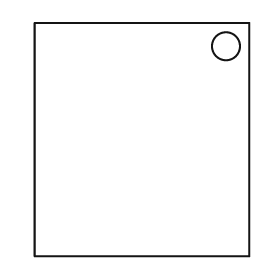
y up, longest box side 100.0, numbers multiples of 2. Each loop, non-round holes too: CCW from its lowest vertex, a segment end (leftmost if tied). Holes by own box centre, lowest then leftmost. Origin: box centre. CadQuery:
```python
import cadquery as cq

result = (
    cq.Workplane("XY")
    .moveTo(-46.0, -50.0)
    .lineTo(46.0, -50.0)
    .lineTo(46.0, 50.0)
    .lineTo(-46.0, 50.0)
    .close()
    .moveTo(36.0, 40.0)
    .circle(6.0)
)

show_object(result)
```